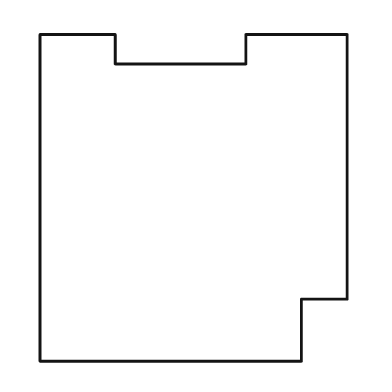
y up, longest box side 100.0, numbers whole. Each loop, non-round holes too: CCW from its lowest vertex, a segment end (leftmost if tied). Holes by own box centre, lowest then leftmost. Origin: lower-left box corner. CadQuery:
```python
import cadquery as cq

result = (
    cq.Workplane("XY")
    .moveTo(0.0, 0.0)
    .lineTo(80.0, 0.0)
    .lineTo(80.0, 19.0)
    .lineTo(94.0, 19.0)
    .lineTo(94.0, 100.0)
    .lineTo(63.0, 100.0)
    .lineTo(63.0, 91.0)
    .lineTo(23.0, 91.0)
    .lineTo(23.0, 100.0)
    .lineTo(0.0, 100.0)
    .close()
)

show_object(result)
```